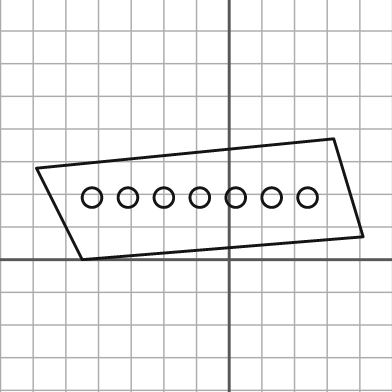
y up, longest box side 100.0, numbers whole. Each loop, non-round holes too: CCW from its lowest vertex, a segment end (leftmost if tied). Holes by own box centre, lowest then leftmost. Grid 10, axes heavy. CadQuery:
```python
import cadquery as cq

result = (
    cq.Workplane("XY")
    .moveTo(-45.0, 0.0)
    .lineTo(41.0, 7.0)
    .lineTo(32.0, 37.0)
    .lineTo(-59.0, 28.0)
    .close()
    .moveTo(-42.0, 19.0)
    .circle(3.0)
    .moveTo(-31.0, 19.0)
    .circle(3.0)
    .moveTo(-20.0, 19.0)
    .circle(3.0)
    .moveTo(-9.0, 19.0)
    .circle(3.0)
    .moveTo(2.0, 19.0)
    .circle(3.0)
    .moveTo(13.0, 19.0)
    .circle(3.0)
    .moveTo(24.0, 19.0)
    .circle(3.0)
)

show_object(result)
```